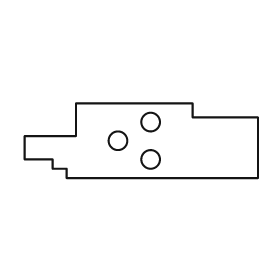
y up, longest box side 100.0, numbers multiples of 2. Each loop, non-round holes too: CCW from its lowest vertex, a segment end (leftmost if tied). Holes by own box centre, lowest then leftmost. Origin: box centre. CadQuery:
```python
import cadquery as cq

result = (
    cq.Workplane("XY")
    .moveTo(-32.0, -16.0)
    .lineTo(50.0, -16.0)
    .lineTo(50.0, 10.0)
    .lineTo(22.0, 10.0)
    .lineTo(22.0, 16.0)
    .lineTo(-28.0, 16.0)
    .lineTo(-28.0, 2.0)
    .lineTo(-50.0, 2.0)
    .lineTo(-50.0, -8.0)
    .lineTo(-38.0, -8.0)
    .lineTo(-38.0, -12.0)
    .lineTo(-32.0, -12.0)
    .close()
    .moveTo(4.0, -8.0)
    .circle(4.0)
    .moveTo(-10.0, 0.0)
    .circle(4.0)
    .moveTo(4.0, 8.0)
    .circle(4.0)
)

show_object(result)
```